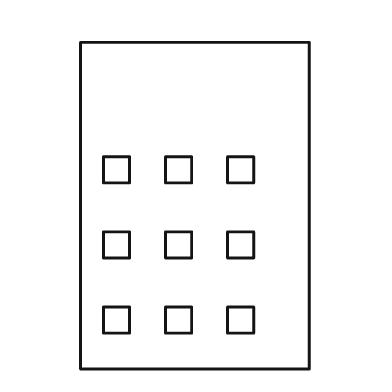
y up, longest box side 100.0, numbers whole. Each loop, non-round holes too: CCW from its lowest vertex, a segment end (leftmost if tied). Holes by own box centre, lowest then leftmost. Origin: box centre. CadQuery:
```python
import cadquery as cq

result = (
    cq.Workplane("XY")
    .moveTo(-35.0, -50.0)
    .lineTo(35.0, -50.0)
    .lineTo(35.0, 50.0)
    .lineTo(-35.0, 50.0)
    .close()
    .moveTo(-28.0, -39.0)
    .lineTo(-20.0, -39.0)
    .lineTo(-20.0, -31.0)
    .lineTo(-28.0, -31.0)
    .close()
    .moveTo(-9.0, -39.0)
    .lineTo(-1.0, -39.0)
    .lineTo(-1.0, -31.0)
    .lineTo(-9.0, -31.0)
    .close()
    .moveTo(10.0, -39.0)
    .lineTo(18.0, -39.0)
    .lineTo(18.0, -31.0)
    .lineTo(10.0, -31.0)
    .close()
    .moveTo(-28.0, -16.0)
    .lineTo(-20.0, -16.0)
    .lineTo(-20.0, -8.0)
    .lineTo(-28.0, -8.0)
    .close()
    .moveTo(-9.0, -16.0)
    .lineTo(-1.0, -16.0)
    .lineTo(-1.0, -8.0)
    .lineTo(-9.0, -8.0)
    .close()
    .moveTo(10.0, -16.0)
    .lineTo(18.0, -16.0)
    .lineTo(18.0, -8.0)
    .lineTo(10.0, -8.0)
    .close()
    .moveTo(-28.0, 7.0)
    .lineTo(-20.0, 7.0)
    .lineTo(-20.0, 15.0)
    .lineTo(-28.0, 15.0)
    .close()
    .moveTo(-9.0, 7.0)
    .lineTo(-1.0, 7.0)
    .lineTo(-1.0, 15.0)
    .lineTo(-9.0, 15.0)
    .close()
    .moveTo(10.0, 7.0)
    .lineTo(18.0, 7.0)
    .lineTo(18.0, 15.0)
    .lineTo(10.0, 15.0)
    .close()
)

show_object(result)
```